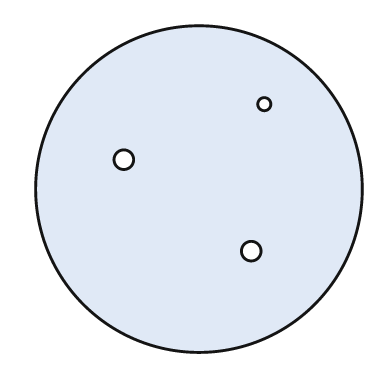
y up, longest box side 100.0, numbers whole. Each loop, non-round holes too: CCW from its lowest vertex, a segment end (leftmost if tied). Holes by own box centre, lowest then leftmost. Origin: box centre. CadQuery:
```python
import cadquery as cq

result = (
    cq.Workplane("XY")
    .moveTo(0.0, 0.0)
    .circle(50.0)
    .moveTo(16.0, -19.0)
    .circle(3.0)
    .moveTo(-23.0, 9.0)
    .circle(3.0)
    .moveTo(20.0, 26.0)
    .circle(2.0)
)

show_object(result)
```